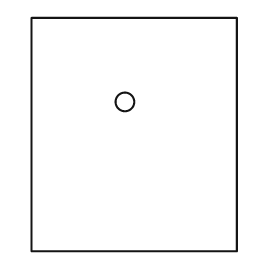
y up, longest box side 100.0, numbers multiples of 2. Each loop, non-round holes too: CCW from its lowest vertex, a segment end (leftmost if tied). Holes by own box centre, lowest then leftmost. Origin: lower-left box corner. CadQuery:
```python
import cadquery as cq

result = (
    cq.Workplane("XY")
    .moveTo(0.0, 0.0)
    .lineTo(88.0, 0.0)
    .lineTo(88.0, 100.0)
    .lineTo(0.0, 100.0)
    .close()
    .moveTo(40.0, 64.0)
    .circle(4.0)
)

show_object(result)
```